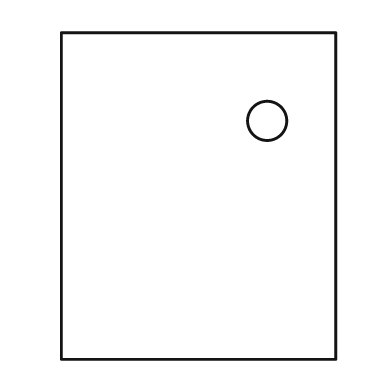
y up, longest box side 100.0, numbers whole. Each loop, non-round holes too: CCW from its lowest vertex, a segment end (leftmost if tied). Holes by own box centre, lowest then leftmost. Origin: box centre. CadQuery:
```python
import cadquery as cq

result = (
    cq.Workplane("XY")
    .moveTo(-42.0, -50.0)
    .lineTo(42.0, -50.0)
    .lineTo(42.0, 50.0)
    .lineTo(-42.0, 50.0)
    .close()
    .moveTo(21.0, 23.0)
    .circle(6.0)
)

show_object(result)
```